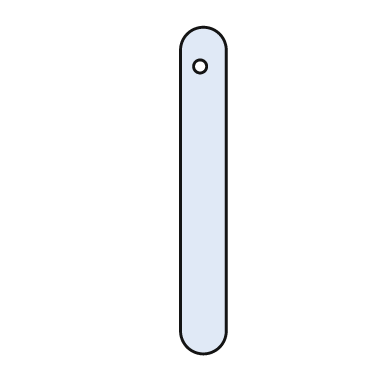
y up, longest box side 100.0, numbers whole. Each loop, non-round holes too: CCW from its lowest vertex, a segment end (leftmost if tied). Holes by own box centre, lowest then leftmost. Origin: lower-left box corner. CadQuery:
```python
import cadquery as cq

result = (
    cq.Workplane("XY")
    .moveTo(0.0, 7.0)
    .threePointArc((7.0, 0.0), (14.0, 7.0))
    .lineTo(14.0, 93.0)
    .threePointArc((7.0, 100.0), (0.0, 93.0))
    .close()
    .moveTo(6.0, 88.0)
    .circle(2.0)
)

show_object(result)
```